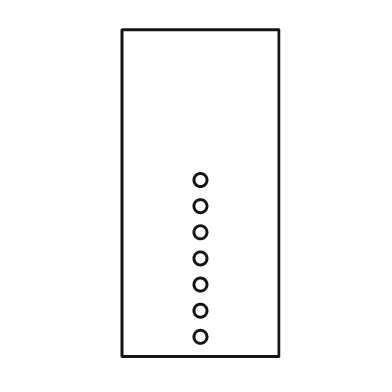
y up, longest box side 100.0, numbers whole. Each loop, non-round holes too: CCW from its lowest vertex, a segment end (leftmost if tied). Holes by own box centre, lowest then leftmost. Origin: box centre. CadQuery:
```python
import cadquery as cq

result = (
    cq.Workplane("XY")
    .moveTo(-24.0, -50.0)
    .lineTo(24.0, -50.0)
    .lineTo(24.0, 50.0)
    .lineTo(-24.0, 50.0)
    .close()
    .moveTo(0.0, -44.0)
    .circle(2.0)
    .moveTo(0.0, -36.0)
    .circle(2.0)
    .moveTo(0.0, -28.0)
    .circle(2.0)
    .moveTo(0.0, -20.0)
    .circle(2.0)
    .moveTo(0.0, -12.0)
    .circle(2.0)
    .moveTo(0.0, -4.0)
    .circle(2.0)
    .moveTo(0.0, 4.0)
    .circle(2.0)
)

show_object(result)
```